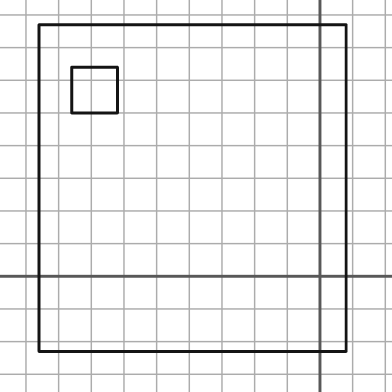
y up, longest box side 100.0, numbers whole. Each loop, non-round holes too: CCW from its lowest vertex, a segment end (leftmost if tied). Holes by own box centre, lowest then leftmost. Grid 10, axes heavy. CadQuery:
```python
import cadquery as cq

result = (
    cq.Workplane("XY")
    .moveTo(-86.0, -23.0)
    .lineTo(8.0, -23.0)
    .lineTo(8.0, 77.0)
    .lineTo(-86.0, 77.0)
    .close()
    .moveTo(-76.0, 50.0)
    .lineTo(-62.0, 50.0)
    .lineTo(-62.0, 64.0)
    .lineTo(-76.0, 64.0)
    .close()
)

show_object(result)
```